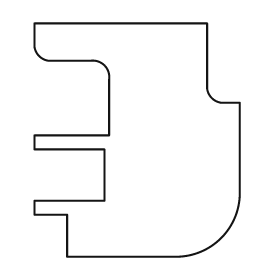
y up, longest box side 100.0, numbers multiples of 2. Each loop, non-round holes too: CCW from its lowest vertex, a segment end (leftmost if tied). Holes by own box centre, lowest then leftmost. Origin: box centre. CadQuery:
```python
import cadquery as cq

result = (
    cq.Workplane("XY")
    .moveTo(-30.0, -50.0)
    .lineTo(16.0, -50.0)
    .threePointArc((36.0, -42.0), (44.0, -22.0))
    .lineTo(44.0, 16.0)
    .lineTo(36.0, 16.0)
    .threePointArc((32.0, 18.0), (30.0, 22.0))
    .lineTo(30.0, 50.0)
    .lineTo(-44.0, 50.0)
    .lineTo(-44.0, 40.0)
    .threePointArc((-42.0, 36.0), (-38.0, 34.0))
    .lineTo(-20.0, 34.0)
    .threePointArc((-14.0, 32.0), (-12.0, 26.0))
    .lineTo(-12.0, 2.0)
    .lineTo(-44.0, 2.0)
    .lineTo(-44.0, -4.0)
    .lineTo(-14.0, -4.0)
    .lineTo(-14.0, -26.0)
    .lineTo(-44.0, -26.0)
    .lineTo(-44.0, -32.0)
    .lineTo(-30.0, -32.0)
    .close()
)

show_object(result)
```